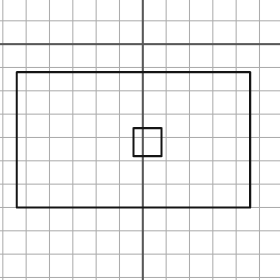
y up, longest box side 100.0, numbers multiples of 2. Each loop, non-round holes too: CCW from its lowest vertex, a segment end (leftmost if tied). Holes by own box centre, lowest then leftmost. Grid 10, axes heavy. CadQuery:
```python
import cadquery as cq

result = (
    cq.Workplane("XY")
    .moveTo(-54.0, -70.0)
    .lineTo(46.0, -70.0)
    .lineTo(46.0, -12.0)
    .lineTo(-54.0, -12.0)
    .close()
    .moveTo(-4.0, -48.0)
    .lineTo(8.0, -48.0)
    .lineTo(8.0, -36.0)
    .lineTo(-4.0, -36.0)
    .close()
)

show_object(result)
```